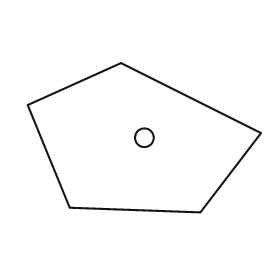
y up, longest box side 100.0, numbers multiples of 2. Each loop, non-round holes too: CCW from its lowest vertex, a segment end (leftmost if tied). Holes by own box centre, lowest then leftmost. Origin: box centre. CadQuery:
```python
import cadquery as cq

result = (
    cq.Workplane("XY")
    .moveTo(24.0, -32.0)
    .lineTo(50.0, 2.0)
    .lineTo(-10.0, 32.0)
    .lineTo(-50.0, 14.0)
    .lineTo(-32.0, -30.0)
    .close()
    .moveTo(0.0, 0.0)
    .circle(4.0)
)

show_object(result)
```